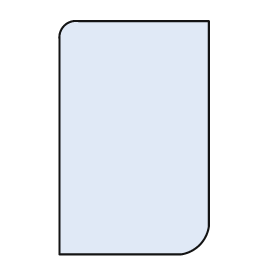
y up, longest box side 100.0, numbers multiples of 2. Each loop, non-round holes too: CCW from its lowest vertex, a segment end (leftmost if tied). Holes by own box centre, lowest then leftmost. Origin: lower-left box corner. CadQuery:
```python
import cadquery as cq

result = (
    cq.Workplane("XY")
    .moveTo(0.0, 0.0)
    .lineTo(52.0, 0.0)
    .threePointArc((60.0, 4.0), (64.0, 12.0))
    .lineTo(64.0, 100.0)
    .lineTo(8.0, 100.0)
    .threePointArc((2.0, 98.0), (0.0, 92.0))
    .close()
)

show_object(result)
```